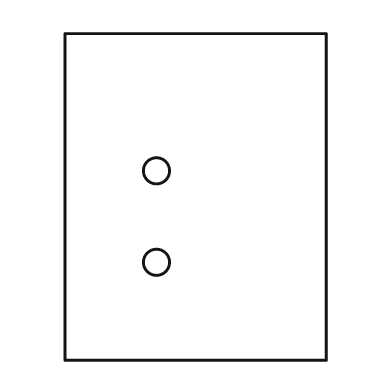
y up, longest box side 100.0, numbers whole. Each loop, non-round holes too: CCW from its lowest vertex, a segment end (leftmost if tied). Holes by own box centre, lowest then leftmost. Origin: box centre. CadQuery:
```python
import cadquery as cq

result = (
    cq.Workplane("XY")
    .moveTo(-40.0, -50.0)
    .lineTo(40.0, -50.0)
    .lineTo(40.0, 50.0)
    .lineTo(-40.0, 50.0)
    .close()
    .moveTo(-12.0, -20.0)
    .circle(4.0)
    .moveTo(-12.0, 8.0)
    .circle(4.0)
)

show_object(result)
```